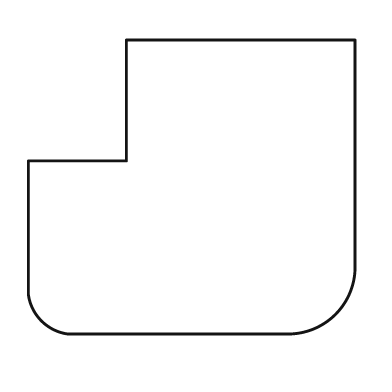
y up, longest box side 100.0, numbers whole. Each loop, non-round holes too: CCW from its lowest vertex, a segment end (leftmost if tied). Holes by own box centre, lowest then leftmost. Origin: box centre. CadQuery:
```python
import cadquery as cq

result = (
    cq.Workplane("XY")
    .moveTo(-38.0, -45.0)
    .lineTo(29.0, -45.0)
    .threePointArc((44.0, -39.0), (50.0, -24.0))
    .lineTo(50.0, 45.0)
    .lineTo(-20.0, 45.0)
    .lineTo(-20.0, 8.0)
    .lineTo(-50.0, 8.0)
    .lineTo(-50.0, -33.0)
    .threePointArc((-46.0, -41.0), (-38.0, -45.0))
    .close()
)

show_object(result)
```